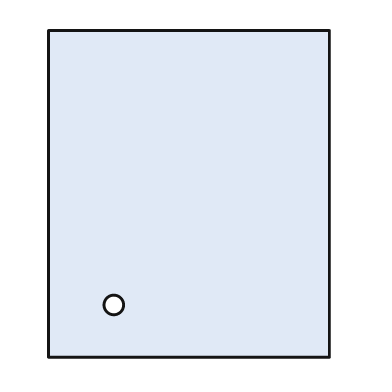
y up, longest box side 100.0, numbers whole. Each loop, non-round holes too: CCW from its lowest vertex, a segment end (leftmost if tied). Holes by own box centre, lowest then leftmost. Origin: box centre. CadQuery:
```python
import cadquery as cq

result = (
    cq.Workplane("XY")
    .moveTo(-43.0, -50.0)
    .lineTo(43.0, -50.0)
    .lineTo(43.0, 50.0)
    .lineTo(-43.0, 50.0)
    .close()
    .moveTo(-23.0, -34.0)
    .circle(3.0)
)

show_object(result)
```